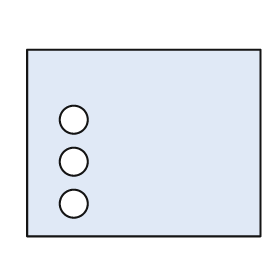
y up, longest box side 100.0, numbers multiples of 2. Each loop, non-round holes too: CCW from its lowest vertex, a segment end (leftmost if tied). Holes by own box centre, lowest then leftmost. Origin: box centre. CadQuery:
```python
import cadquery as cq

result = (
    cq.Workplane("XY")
    .moveTo(-50.0, -40.0)
    .lineTo(50.0, -40.0)
    .lineTo(50.0, 40.0)
    .lineTo(-50.0, 40.0)
    .close()
    .moveTo(-30.0, -26.0)
    .circle(6.0)
    .moveTo(-30.0, -8.0)
    .circle(6.0)
    .moveTo(-30.0, 10.0)
    .circle(6.0)
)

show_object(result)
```